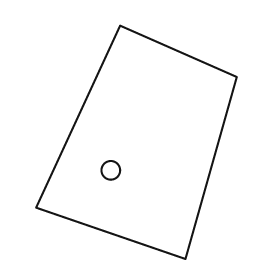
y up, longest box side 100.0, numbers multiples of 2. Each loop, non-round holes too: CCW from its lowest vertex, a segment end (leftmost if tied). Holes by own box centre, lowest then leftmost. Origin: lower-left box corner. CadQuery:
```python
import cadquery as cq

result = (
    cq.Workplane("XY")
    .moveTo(64.0, 0.0)
    .lineTo(86.0, 78.0)
    .lineTo(36.0, 100.0)
    .lineTo(0.0, 22.0)
    .close()
    .moveTo(32.0, 38.0)
    .circle(4.0)
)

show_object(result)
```